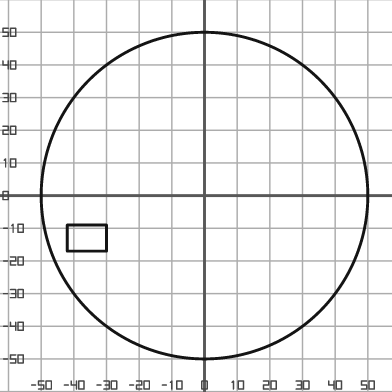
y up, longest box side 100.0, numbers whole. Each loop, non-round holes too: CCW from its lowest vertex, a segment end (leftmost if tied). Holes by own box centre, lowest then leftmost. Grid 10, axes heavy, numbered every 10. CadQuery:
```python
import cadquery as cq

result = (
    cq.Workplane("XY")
    .moveTo(0.0, 0.0)
    .circle(50.0)
    .moveTo(-42.0, -17.0)
    .lineTo(-30.0, -17.0)
    .lineTo(-30.0, -9.0)
    .lineTo(-42.0, -9.0)
    .close()
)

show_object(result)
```